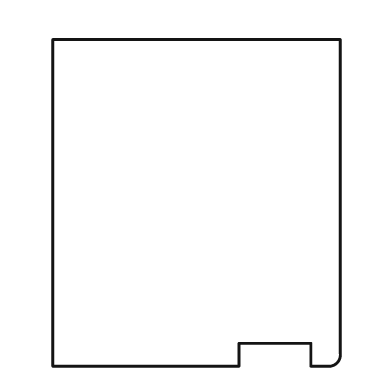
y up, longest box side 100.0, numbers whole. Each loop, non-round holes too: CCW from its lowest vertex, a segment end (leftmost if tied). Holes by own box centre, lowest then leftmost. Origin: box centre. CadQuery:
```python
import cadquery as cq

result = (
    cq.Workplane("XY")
    .moveTo(-44.0, -50.0)
    .lineTo(13.0, -50.0)
    .lineTo(13.0, -43.0)
    .lineTo(35.0, -43.0)
    .lineTo(35.0, -50.0)
    .lineTo(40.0, -50.0)
    .threePointArc((43.0, -49.0), (44.0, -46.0))
    .lineTo(44.0, 50.0)
    .lineTo(-44.0, 50.0)
    .close()
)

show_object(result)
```